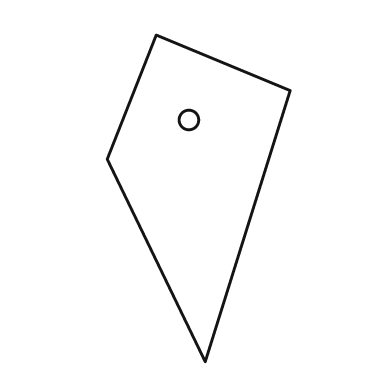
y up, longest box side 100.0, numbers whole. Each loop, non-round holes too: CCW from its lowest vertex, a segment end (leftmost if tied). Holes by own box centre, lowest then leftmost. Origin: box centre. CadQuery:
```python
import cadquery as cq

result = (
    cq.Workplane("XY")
    .moveTo(2.0, -50.0)
    .lineTo(28.0, 33.0)
    .lineTo(-13.0, 50.0)
    .lineTo(-28.0, 12.0)
    .close()
    .moveTo(-3.0, 24.0)
    .circle(3.0)
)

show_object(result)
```